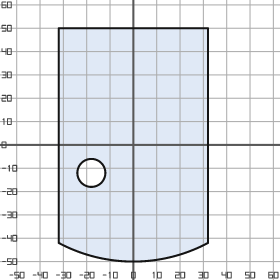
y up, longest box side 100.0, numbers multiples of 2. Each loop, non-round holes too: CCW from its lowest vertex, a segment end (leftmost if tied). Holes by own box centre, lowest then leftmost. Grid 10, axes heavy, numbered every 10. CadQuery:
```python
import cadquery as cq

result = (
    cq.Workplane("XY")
    .moveTo(-32.0, -42.0)
    .threePointArc((0.0, -50.0), (32.0, -42.0))
    .lineTo(32.0, 50.0)
    .lineTo(-32.0, 50.0)
    .close()
    .moveTo(-18.0, -12.0)
    .circle(6.0)
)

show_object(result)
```